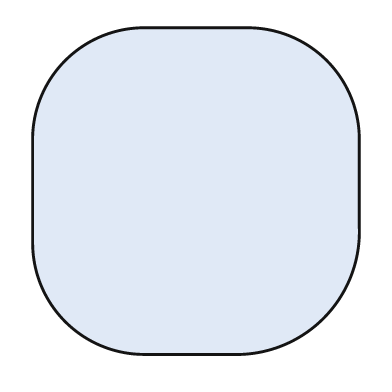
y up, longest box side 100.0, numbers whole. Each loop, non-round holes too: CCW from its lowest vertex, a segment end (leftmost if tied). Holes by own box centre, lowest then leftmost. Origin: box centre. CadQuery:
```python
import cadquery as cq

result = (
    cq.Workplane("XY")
    .moveTo(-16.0, -50.0)
    .lineTo(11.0, -50.0)
    .threePointArc((39.0, -39.0), (50.0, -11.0))
    .lineTo(50.0, 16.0)
    .threePointArc((40.0, 40.0), (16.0, 50.0))
    .lineTo(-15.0, 50.0)
    .threePointArc((-40.0, 40.0), (-50.0, 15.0))
    .lineTo(-50.0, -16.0)
    .threePointArc((-40.0, -40.0), (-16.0, -50.0))
    .close()
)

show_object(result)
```